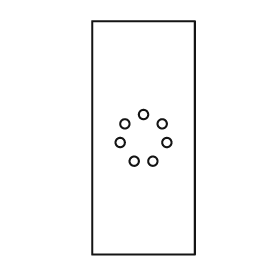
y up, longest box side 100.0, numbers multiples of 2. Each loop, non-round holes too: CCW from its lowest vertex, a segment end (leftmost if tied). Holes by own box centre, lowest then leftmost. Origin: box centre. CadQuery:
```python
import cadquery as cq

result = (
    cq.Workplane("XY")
    .moveTo(-22.0, -50.0)
    .lineTo(22.0, -50.0)
    .lineTo(22.0, 50.0)
    .lineTo(-22.0, 50.0)
    .close()
    .moveTo(-4.0, -10.0)
    .circle(2.0)
    .moveTo(4.0, -10.0)
    .circle(2.0)
    .moveTo(-10.0, -2.0)
    .circle(2.0)
    .moveTo(10.0, -2.0)
    .circle(2.0)
    .moveTo(-8.0, 6.0)
    .circle(2.0)
    .moveTo(8.0, 6.0)
    .circle(2.0)
    .moveTo(0.0, 10.0)
    .circle(2.0)
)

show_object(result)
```